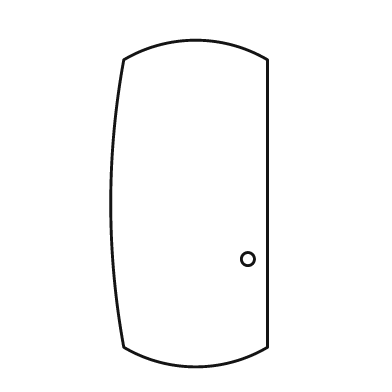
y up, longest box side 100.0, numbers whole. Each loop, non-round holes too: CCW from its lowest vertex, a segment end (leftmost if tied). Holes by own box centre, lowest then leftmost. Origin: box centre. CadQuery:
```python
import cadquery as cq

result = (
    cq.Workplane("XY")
    .moveTo(-20.0, -44.0)
    .threePointArc((2.0, -50.0), (24.0, -44.0))
    .lineTo(24.0, 44.0)
    .threePointArc((2.0, 50.0), (-20.0, 44.0))
    .threePointArc((-24.0, 0.0), (-20.0, -44.0))
    .close()
    .moveTo(18.0, -17.0)
    .circle(2.0)
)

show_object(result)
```